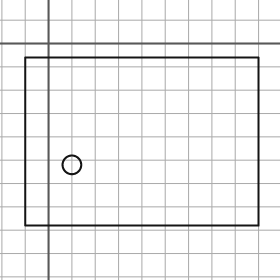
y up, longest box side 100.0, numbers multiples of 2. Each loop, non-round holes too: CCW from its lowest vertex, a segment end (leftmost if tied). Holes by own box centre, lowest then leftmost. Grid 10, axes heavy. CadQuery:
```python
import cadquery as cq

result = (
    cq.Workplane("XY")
    .moveTo(-10.0, -78.0)
    .lineTo(90.0, -78.0)
    .lineTo(90.0, -6.0)
    .lineTo(-10.0, -6.0)
    .close()
    .moveTo(10.0, -52.0)
    .circle(4.0)
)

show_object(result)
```